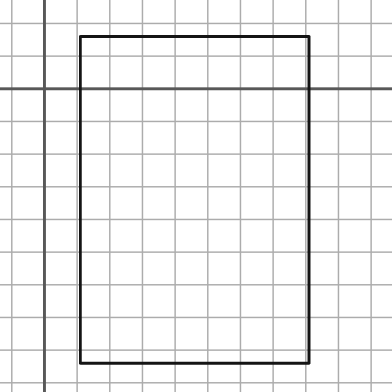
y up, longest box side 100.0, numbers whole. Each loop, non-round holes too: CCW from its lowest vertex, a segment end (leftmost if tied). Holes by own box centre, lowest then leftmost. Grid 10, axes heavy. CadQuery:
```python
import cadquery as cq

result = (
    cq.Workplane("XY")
    .moveTo(11.0, -84.0)
    .lineTo(81.0, -84.0)
    .lineTo(81.0, 16.0)
    .lineTo(11.0, 16.0)
    .close()
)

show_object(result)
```